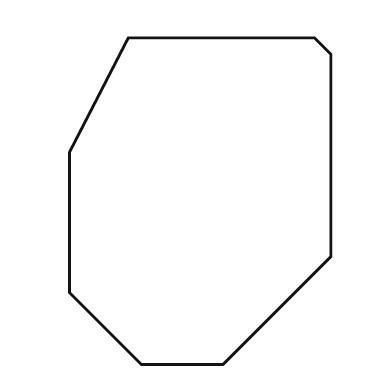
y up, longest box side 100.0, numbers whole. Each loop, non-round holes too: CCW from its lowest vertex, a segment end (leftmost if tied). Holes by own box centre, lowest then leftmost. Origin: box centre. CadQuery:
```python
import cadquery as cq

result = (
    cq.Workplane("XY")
    .moveTo(-18.0, -50.0)
    .lineTo(7.0, -50.0)
    .lineTo(40.0, -17.0)
    .lineTo(40.0, 45.0)
    .lineTo(35.0, 50.0)
    .lineTo(-22.0, 50.0)
    .lineTo(-40.0, 15.0)
    .lineTo(-40.0, -28.0)
    .close()
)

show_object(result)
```